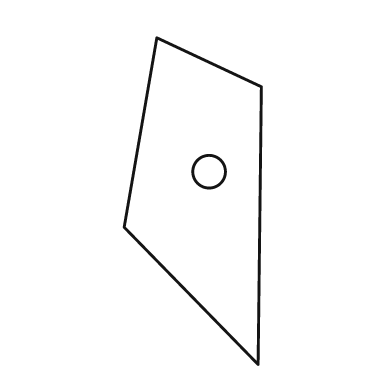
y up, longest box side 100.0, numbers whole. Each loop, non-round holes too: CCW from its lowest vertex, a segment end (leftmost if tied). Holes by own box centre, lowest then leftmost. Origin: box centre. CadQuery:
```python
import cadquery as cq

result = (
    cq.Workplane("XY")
    .moveTo(20.0, -50.0)
    .lineTo(21.0, 35.0)
    .lineTo(-11.0, 50.0)
    .lineTo(-21.0, -8.0)
    .close()
    .moveTo(5.0, 9.0)
    .circle(5.0)
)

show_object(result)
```